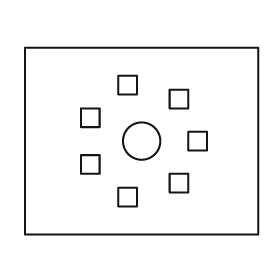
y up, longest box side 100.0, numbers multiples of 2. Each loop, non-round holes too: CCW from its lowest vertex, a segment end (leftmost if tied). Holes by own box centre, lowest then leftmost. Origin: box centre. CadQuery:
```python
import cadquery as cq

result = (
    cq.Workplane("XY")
    .moveTo(-50.0, -40.0)
    .lineTo(50.0, -40.0)
    .lineTo(50.0, 40.0)
    .lineTo(-50.0, 40.0)
    .close()
    .moveTo(-10.0, -28.0)
    .lineTo(-2.0, -28.0)
    .lineTo(-2.0, -20.0)
    .lineTo(-10.0, -20.0)
    .close()
    .moveTo(12.0, -22.0)
    .lineTo(20.0, -22.0)
    .lineTo(20.0, -14.0)
    .lineTo(12.0, -14.0)
    .close()
    .moveTo(-26.0, -14.0)
    .lineTo(-18.0, -14.0)
    .lineTo(-18.0, -6.0)
    .lineTo(-26.0, -6.0)
    .close()
    .moveTo(0.0, 0.0)
    .circle(8.0)
    .moveTo(20.0, -4.0)
    .lineTo(28.0, -4.0)
    .lineTo(28.0, 4.0)
    .lineTo(20.0, 4.0)
    .close()
    .moveTo(-26.0, 6.0)
    .lineTo(-18.0, 6.0)
    .lineTo(-18.0, 14.0)
    .lineTo(-26.0, 14.0)
    .close()
    .moveTo(12.0, 14.0)
    .lineTo(20.0, 14.0)
    .lineTo(20.0, 22.0)
    .lineTo(12.0, 22.0)
    .close()
    .moveTo(-10.0, 20.0)
    .lineTo(-2.0, 20.0)
    .lineTo(-2.0, 28.0)
    .lineTo(-10.0, 28.0)
    .close()
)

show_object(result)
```